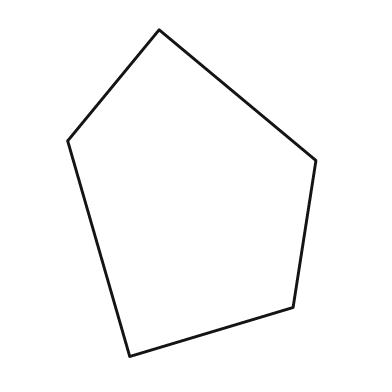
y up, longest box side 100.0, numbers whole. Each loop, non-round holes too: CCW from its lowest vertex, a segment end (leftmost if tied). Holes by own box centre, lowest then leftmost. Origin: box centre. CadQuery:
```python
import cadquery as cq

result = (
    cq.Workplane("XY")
    .moveTo(-19.0, -50.0)
    .lineTo(31.0, -35.0)
    .lineTo(38.0, 10.0)
    .lineTo(-10.0, 50.0)
    .lineTo(-38.0, 16.0)
    .close()
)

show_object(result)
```